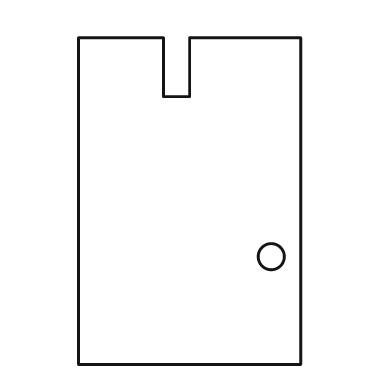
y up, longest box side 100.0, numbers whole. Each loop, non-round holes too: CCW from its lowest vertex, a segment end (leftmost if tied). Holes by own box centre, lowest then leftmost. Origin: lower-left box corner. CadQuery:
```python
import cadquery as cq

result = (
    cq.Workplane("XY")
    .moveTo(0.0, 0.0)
    .lineTo(68.0, 0.0)
    .lineTo(68.0, 100.0)
    .lineTo(34.0, 100.0)
    .lineTo(34.0, 82.0)
    .lineTo(26.0, 82.0)
    .lineTo(26.0, 100.0)
    .lineTo(0.0, 100.0)
    .close()
    .moveTo(59.0, 33.0)
    .circle(4.0)
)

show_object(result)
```